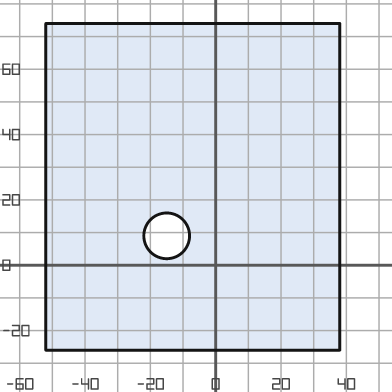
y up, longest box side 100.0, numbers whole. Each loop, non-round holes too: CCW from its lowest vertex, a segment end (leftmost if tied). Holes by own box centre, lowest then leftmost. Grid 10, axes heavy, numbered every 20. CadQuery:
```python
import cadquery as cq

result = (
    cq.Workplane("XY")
    .moveTo(-52.0, -26.0)
    .lineTo(38.0, -26.0)
    .lineTo(38.0, 74.0)
    .lineTo(-52.0, 74.0)
    .close()
    .moveTo(-15.0, 9.0)
    .circle(7.0)
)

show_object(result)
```